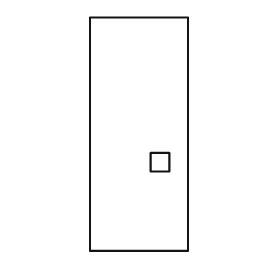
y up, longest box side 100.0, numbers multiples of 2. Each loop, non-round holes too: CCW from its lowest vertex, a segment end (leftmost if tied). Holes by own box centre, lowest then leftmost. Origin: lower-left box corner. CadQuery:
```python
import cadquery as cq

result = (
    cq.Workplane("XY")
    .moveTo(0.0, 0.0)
    .lineTo(42.0, 0.0)
    .lineTo(42.0, 100.0)
    .lineTo(0.0, 100.0)
    .close()
    .moveTo(26.0, 34.0)
    .lineTo(34.0, 34.0)
    .lineTo(34.0, 42.0)
    .lineTo(26.0, 42.0)
    .close()
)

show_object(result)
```